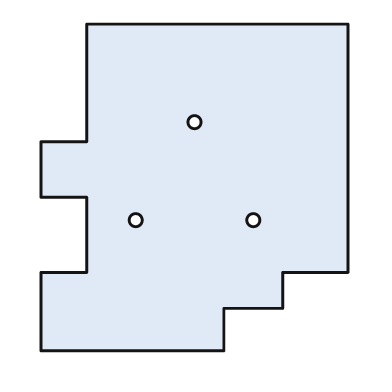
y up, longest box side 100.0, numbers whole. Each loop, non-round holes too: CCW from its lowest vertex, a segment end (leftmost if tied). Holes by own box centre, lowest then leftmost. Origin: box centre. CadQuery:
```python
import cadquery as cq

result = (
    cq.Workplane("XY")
    .moveTo(-47.0, -50.0)
    .lineTo(9.0, -50.0)
    .lineTo(9.0, -37.0)
    .lineTo(27.0, -37.0)
    .lineTo(27.0, -26.0)
    .lineTo(47.0, -26.0)
    .lineTo(47.0, 50.0)
    .lineTo(-33.0, 50.0)
    .lineTo(-33.0, 14.0)
    .lineTo(-47.0, 14.0)
    .lineTo(-47.0, -3.0)
    .lineTo(-33.0, -3.0)
    .lineTo(-33.0, -26.0)
    .lineTo(-47.0, -26.0)
    .close()
    .moveTo(-18.0, -10.0)
    .circle(2.0)
    .moveTo(18.0, -10.0)
    .circle(2.0)
    .moveTo(0.0, 20.0)
    .circle(2.0)
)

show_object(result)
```